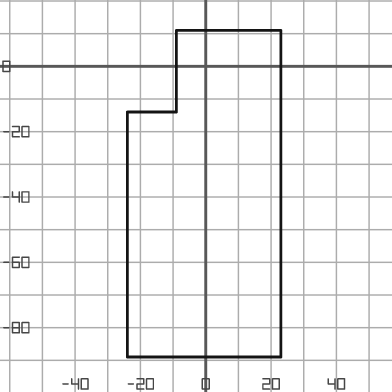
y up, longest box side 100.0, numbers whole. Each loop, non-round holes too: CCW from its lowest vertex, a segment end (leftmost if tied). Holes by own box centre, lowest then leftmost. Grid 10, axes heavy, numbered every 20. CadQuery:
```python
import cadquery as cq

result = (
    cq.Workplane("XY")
    .moveTo(-24.0, -89.0)
    .lineTo(23.0, -89.0)
    .lineTo(23.0, 11.0)
    .lineTo(-9.0, 11.0)
    .lineTo(-9.0, -14.0)
    .lineTo(-24.0, -14.0)
    .close()
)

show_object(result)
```